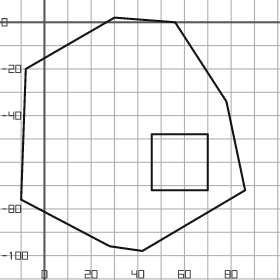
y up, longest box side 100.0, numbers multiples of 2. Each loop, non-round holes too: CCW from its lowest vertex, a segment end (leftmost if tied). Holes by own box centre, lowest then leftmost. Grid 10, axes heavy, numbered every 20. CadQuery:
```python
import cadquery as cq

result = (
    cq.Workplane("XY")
    .moveTo(42.0, -98.0)
    .lineTo(86.0, -72.0)
    .lineTo(78.0, -34.0)
    .lineTo(56.0, 0.0)
    .lineTo(30.0, 2.0)
    .lineTo(-8.0, -20.0)
    .lineTo(-10.0, -76.0)
    .lineTo(28.0, -96.0)
    .close()
    .moveTo(46.0, -72.0)
    .lineTo(70.0, -72.0)
    .lineTo(70.0, -48.0)
    .lineTo(46.0, -48.0)
    .close()
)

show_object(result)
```